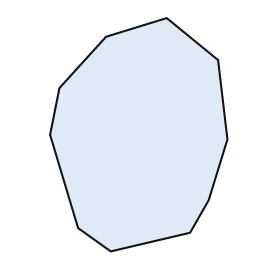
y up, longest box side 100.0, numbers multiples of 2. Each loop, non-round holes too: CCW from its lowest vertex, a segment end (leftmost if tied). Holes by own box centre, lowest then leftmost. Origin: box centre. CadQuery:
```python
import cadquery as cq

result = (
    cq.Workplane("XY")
    .moveTo(-12.0, -50.0)
    .lineTo(22.0, -42.0)
    .lineTo(30.0, -28.0)
    .lineTo(38.0, -2.0)
    .lineTo(34.0, 32.0)
    .lineTo(12.0, 50.0)
    .lineTo(-14.0, 42.0)
    .lineTo(-34.0, 20.0)
    .lineTo(-38.0, 0.0)
    .lineTo(-26.0, -40.0)
    .close()
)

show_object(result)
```